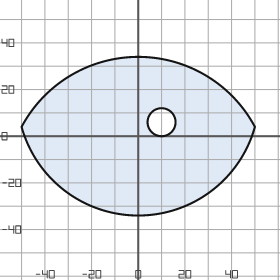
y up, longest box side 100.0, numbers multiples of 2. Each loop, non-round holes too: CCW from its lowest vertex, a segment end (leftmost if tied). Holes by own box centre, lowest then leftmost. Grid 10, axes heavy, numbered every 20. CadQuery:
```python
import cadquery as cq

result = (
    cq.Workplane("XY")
    .moveTo(-50.0, 4.0)
    .threePointArc((0.0, -34.0), (50.0, 4.0))
    .threePointArc((0.0, 34.0), (-50.0, 4.0))
    .close()
    .moveTo(10.0, 6.0)
    .circle(6.0)
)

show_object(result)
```